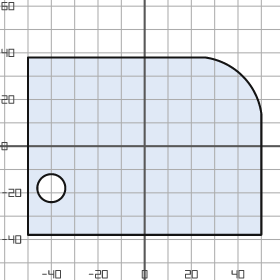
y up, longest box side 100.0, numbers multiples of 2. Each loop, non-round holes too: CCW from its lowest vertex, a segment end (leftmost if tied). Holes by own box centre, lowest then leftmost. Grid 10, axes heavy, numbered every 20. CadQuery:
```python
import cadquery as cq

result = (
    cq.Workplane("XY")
    .moveTo(-50.0, -38.0)
    .lineTo(50.0, -38.0)
    .lineTo(50.0, 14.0)
    .threePointArc((42.0, 30.0), (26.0, 38.0))
    .lineTo(-50.0, 38.0)
    .close()
    .moveTo(-40.0, -18.0)
    .circle(6.0)
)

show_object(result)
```